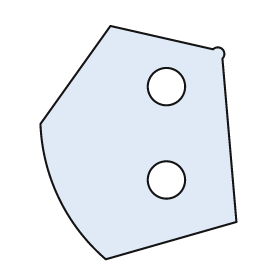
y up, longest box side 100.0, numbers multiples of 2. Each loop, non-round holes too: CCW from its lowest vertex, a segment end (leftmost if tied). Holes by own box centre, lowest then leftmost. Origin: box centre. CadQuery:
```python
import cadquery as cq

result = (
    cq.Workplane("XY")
    .moveTo(-14.0, -50.0)
    .lineTo(42.0, -34.0)
    .lineTo(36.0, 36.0)
    .threePointArc((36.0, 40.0), (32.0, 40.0))
    .lineTo(-12.0, 50.0)
    .lineTo(-42.0, 8.0)
    .threePointArc((-34.0, -24.0), (-14.0, -50.0))
    .close()
    .moveTo(12.0, -16.0)
    .circle(8.0)
    .moveTo(12.0, 24.0)
    .circle(8.0)
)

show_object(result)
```